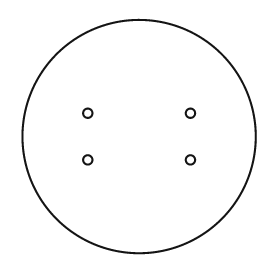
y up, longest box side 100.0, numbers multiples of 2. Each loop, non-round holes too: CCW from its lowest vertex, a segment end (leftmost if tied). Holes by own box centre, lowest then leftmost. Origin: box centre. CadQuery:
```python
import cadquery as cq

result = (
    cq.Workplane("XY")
    .moveTo(0.0, 0.0)
    .circle(50.0)
    .moveTo(-22.0, -10.0)
    .circle(2.0)
    .moveTo(22.0, -10.0)
    .circle(2.0)
    .moveTo(-22.0, 10.0)
    .circle(2.0)
    .moveTo(22.0, 10.0)
    .circle(2.0)
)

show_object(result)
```